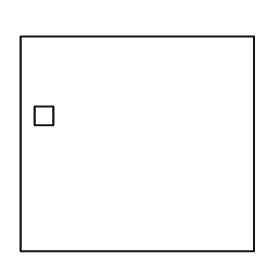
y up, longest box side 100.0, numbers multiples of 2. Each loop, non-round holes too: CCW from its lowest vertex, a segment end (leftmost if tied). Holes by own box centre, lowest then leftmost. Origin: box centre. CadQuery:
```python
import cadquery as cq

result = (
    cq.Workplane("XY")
    .moveTo(-50.0, -46.0)
    .lineTo(50.0, -46.0)
    .lineTo(50.0, 46.0)
    .lineTo(-50.0, 46.0)
    .close()
    .moveTo(-44.0, 8.0)
    .lineTo(-36.0, 8.0)
    .lineTo(-36.0, 16.0)
    .lineTo(-44.0, 16.0)
    .close()
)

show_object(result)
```